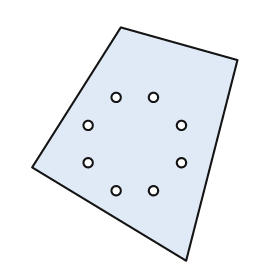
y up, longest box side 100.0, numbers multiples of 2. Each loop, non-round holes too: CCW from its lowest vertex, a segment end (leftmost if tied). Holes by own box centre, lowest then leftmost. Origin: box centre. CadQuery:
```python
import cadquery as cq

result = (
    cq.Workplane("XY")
    .moveTo(22.0, -50.0)
    .lineTo(44.0, 36.0)
    .lineTo(-6.0, 50.0)
    .lineTo(-44.0, -10.0)
    .close()
    .moveTo(-8.0, -20.0)
    .circle(2.0)
    .moveTo(8.0, -20.0)
    .circle(2.0)
    .moveTo(-20.0, -8.0)
    .circle(2.0)
    .moveTo(20.0, -8.0)
    .circle(2.0)
    .moveTo(-20.0, 8.0)
    .circle(2.0)
    .moveTo(20.0, 8.0)
    .circle(2.0)
    .moveTo(-8.0, 20.0)
    .circle(2.0)
    .moveTo(8.0, 20.0)
    .circle(2.0)
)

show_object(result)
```